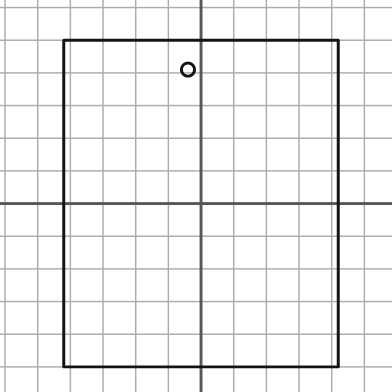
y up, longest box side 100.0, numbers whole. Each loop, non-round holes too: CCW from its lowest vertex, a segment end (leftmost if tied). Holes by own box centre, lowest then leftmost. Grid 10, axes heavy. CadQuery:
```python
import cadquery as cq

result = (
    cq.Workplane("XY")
    .moveTo(-42.0, -50.0)
    .lineTo(42.0, -50.0)
    .lineTo(42.0, 50.0)
    .lineTo(-42.0, 50.0)
    .close()
    .moveTo(-4.0, 41.0)
    .circle(2.0)
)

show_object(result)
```